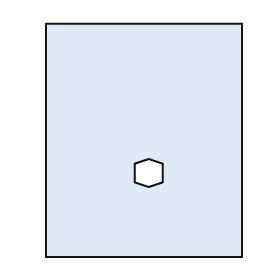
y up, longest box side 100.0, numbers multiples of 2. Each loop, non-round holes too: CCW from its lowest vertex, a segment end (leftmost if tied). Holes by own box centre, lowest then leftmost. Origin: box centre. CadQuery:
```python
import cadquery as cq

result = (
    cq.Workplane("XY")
    .moveTo(-42.0, -50.0)
    .lineTo(42.0, -50.0)
    .lineTo(42.0, 50.0)
    .lineTo(-42.0, 50.0)
    .close()
    .moveTo(2.0, -20.0)
    .lineTo(8.0, -18.0)
    .lineTo(8.0, -10.0)
    .lineTo(2.0, -8.0)
    .lineTo(-4.0, -10.0)
    .lineTo(-4.0, -18.0)
    .close()
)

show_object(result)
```